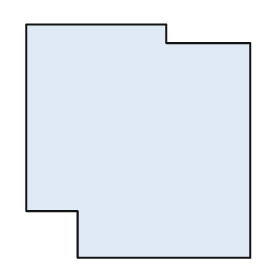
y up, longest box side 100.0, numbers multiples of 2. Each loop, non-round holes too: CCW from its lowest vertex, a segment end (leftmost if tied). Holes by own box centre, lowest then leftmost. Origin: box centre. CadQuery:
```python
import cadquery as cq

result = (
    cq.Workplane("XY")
    .moveTo(-26.0, -50.0)
    .lineTo(48.0, -50.0)
    .lineTo(48.0, 42.0)
    .lineTo(12.0, 42.0)
    .lineTo(12.0, 50.0)
    .lineTo(-48.0, 50.0)
    .lineTo(-48.0, -30.0)
    .lineTo(-26.0, -30.0)
    .close()
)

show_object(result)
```